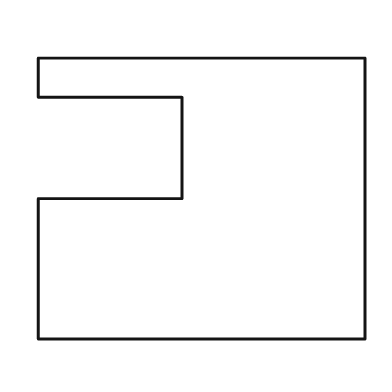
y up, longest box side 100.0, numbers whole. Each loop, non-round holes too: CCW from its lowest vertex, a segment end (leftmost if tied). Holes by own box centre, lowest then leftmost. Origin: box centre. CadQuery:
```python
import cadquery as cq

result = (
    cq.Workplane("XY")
    .moveTo(-50.0, -43.0)
    .lineTo(50.0, -43.0)
    .lineTo(50.0, 43.0)
    .lineTo(-50.0, 43.0)
    .lineTo(-50.0, 31.0)
    .lineTo(-6.0, 31.0)
    .lineTo(-6.0, 0.0)
    .lineTo(-50.0, 0.0)
    .close()
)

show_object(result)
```